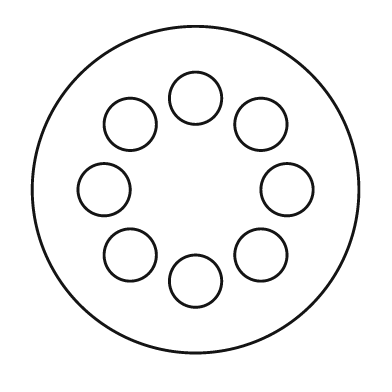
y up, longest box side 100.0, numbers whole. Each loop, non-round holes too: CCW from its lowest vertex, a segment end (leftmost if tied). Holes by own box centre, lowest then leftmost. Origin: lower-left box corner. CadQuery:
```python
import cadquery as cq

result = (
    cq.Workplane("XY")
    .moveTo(50.0, 50.0)
    .circle(50.0)
    .moveTo(50.0, 22.0)
    .circle(8.0)
    .moveTo(30.0, 30.0)
    .circle(8.0)
    .moveTo(70.0, 30.0)
    .circle(8.0)
    .moveTo(22.0, 50.0)
    .circle(8.0)
    .moveTo(78.0, 50.0)
    .circle(8.0)
    .moveTo(30.0, 70.0)
    .circle(8.0)
    .moveTo(70.0, 70.0)
    .circle(8.0)
    .moveTo(50.0, 78.0)
    .circle(8.0)
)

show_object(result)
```